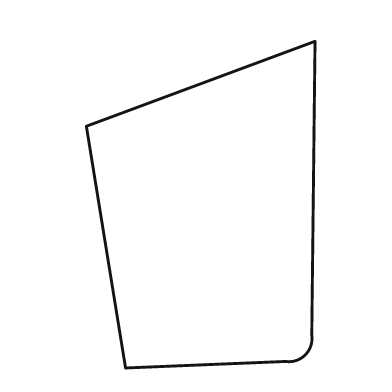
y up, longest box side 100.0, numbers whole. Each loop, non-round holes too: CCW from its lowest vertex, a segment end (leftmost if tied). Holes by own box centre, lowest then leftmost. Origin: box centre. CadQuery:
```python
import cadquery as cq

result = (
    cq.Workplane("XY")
    .moveTo(-23.0, -50.0)
    .lineTo(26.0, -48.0)
    .threePointArc((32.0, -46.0), (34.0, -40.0))
    .lineTo(35.0, 50.0)
    .lineTo(-35.0, 24.0)
    .close()
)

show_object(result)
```